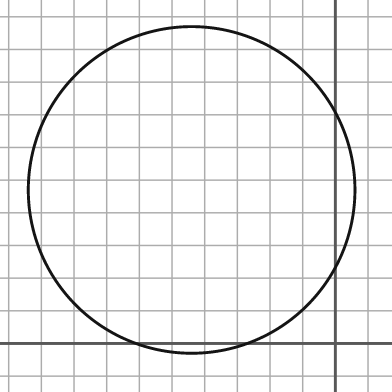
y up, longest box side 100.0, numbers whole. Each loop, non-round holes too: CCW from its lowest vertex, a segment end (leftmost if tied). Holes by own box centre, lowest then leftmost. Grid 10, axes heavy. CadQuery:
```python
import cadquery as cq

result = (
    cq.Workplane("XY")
    .moveTo(-44.0, 47.0)
    .circle(50.0)
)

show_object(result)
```